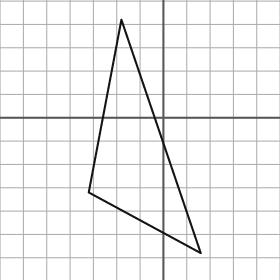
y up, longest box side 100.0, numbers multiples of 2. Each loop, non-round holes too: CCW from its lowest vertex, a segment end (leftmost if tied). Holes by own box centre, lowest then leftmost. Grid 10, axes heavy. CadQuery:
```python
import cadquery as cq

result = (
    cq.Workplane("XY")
    .moveTo(16.0, -58.0)
    .lineTo(-18.0, 42.0)
    .lineTo(-32.0, -32.0)
    .close()
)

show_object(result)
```